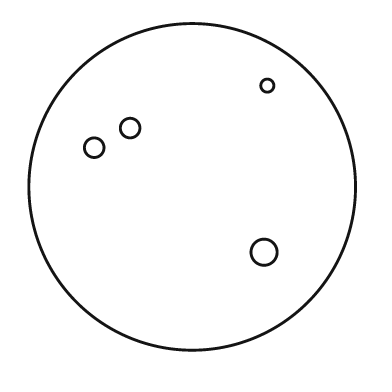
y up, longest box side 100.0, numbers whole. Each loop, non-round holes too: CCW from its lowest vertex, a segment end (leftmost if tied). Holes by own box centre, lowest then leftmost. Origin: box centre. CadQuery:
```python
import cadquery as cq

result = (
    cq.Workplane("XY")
    .moveTo(0.0, 0.0)
    .circle(50.0)
    .moveTo(22.0, -20.0)
    .circle(4.0)
    .moveTo(-30.0, 12.0)
    .circle(3.0)
    .moveTo(-19.0, 18.0)
    .circle(3.0)
    .moveTo(23.0, 31.0)
    .circle(2.0)
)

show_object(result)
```